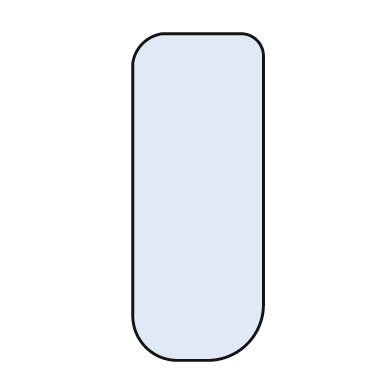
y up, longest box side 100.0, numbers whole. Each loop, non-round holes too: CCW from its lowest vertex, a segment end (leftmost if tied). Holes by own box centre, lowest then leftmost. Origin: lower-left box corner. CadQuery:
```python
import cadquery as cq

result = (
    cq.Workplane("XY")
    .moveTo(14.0, 0.0)
    .lineTo(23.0, 0.0)
    .threePointArc((35.0, 5.0), (40.0, 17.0))
    .lineTo(40.0, 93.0)
    .threePointArc((38.0, 98.0), (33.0, 100.0))
    .lineTo(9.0, 100.0)
    .threePointArc((3.0, 97.0), (0.0, 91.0))
    .lineTo(0.0, 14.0)
    .threePointArc((4.0, 4.0), (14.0, 0.0))
    .close()
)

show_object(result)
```